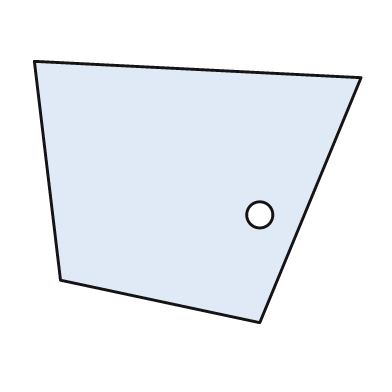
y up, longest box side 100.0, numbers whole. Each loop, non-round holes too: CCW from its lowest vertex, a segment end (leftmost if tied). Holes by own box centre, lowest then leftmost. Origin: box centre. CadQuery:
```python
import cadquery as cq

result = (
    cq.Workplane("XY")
    .moveTo(19.0, -40.0)
    .lineTo(50.0, 35.0)
    .lineTo(-50.0, 40.0)
    .lineTo(-42.0, -27.0)
    .close()
    .moveTo(19.0, -7.0)
    .circle(4.0)
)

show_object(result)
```